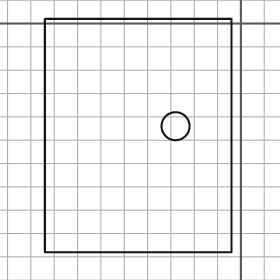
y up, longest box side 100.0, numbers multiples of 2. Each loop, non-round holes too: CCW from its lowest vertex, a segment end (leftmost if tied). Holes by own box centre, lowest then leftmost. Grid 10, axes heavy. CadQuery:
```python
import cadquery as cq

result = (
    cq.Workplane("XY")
    .moveTo(-84.0, -98.0)
    .lineTo(-4.0, -98.0)
    .lineTo(-4.0, 2.0)
    .lineTo(-84.0, 2.0)
    .close()
    .moveTo(-28.0, -44.0)
    .circle(6.0)
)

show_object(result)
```